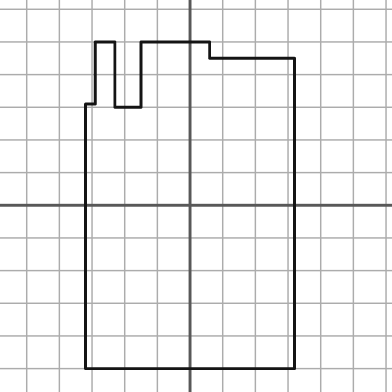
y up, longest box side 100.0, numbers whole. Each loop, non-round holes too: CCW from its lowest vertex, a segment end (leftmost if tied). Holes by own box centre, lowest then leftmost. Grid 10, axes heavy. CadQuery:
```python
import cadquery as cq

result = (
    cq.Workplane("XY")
    .moveTo(-32.0, -50.0)
    .lineTo(32.0, -50.0)
    .lineTo(32.0, 45.0)
    .lineTo(6.0, 45.0)
    .lineTo(6.0, 50.0)
    .lineTo(-15.0, 50.0)
    .lineTo(-15.0, 30.0)
    .lineTo(-23.0, 30.0)
    .lineTo(-23.0, 50.0)
    .lineTo(-29.0, 50.0)
    .lineTo(-29.0, 31.0)
    .lineTo(-32.0, 31.0)
    .close()
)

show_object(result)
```